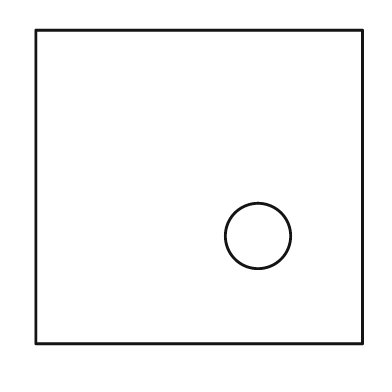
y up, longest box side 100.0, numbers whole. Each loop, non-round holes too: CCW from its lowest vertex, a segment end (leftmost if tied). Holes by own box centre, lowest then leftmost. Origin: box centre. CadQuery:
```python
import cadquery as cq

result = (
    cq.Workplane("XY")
    .moveTo(-50.0, -48.0)
    .lineTo(50.0, -48.0)
    .lineTo(50.0, 48.0)
    .lineTo(-50.0, 48.0)
    .close()
    .moveTo(18.0, -15.0)
    .circle(10.0)
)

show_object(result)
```